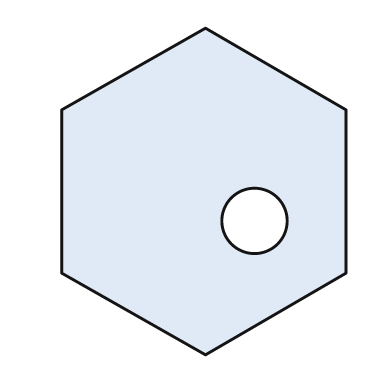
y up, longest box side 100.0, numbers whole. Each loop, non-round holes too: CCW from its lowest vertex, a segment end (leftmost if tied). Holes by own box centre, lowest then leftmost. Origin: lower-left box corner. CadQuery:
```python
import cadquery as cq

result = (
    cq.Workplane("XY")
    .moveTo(44.0, 0.0)
    .lineTo(87.0, 25.0)
    .lineTo(87.0, 75.0)
    .lineTo(44.0, 100.0)
    .lineTo(0.0, 75.0)
    .lineTo(0.0, 25.0)
    .close()
    .moveTo(59.0, 41.0)
    .circle(10.0)
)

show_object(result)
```